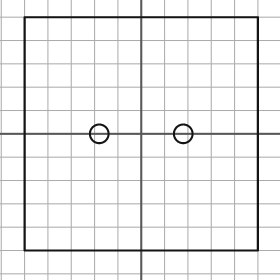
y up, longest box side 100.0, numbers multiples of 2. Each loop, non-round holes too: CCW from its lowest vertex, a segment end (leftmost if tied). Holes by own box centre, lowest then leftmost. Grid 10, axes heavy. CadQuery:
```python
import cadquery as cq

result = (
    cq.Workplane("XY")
    .moveTo(-50.0, -50.0)
    .lineTo(50.0, -50.0)
    .lineTo(50.0, 50.0)
    .lineTo(-50.0, 50.0)
    .close()
    .moveTo(-18.0, 0.0)
    .circle(4.0)
    .moveTo(18.0, 0.0)
    .circle(4.0)
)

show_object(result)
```